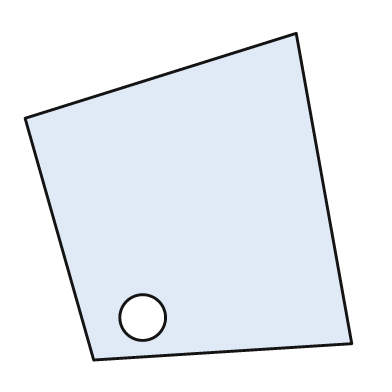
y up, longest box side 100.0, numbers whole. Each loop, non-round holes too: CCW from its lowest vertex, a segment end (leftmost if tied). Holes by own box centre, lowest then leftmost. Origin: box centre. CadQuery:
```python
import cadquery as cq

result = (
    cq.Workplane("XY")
    .moveTo(-29.0, -50.0)
    .lineTo(50.0, -45.0)
    .lineTo(33.0, 50.0)
    .lineTo(-50.0, 24.0)
    .close()
    .moveTo(-14.0, -37.0)
    .circle(7.0)
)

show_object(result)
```